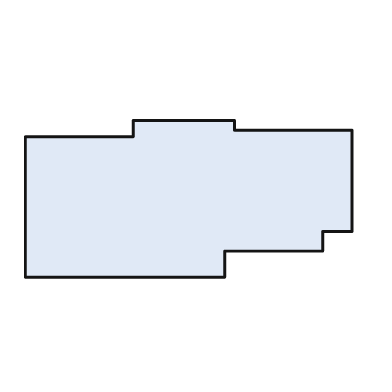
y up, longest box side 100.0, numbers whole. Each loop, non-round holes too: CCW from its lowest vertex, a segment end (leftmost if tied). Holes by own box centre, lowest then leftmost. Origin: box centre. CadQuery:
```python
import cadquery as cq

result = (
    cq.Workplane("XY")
    .moveTo(-50.0, -24.0)
    .lineTo(11.0, -24.0)
    .lineTo(11.0, -16.0)
    .lineTo(41.0, -16.0)
    .lineTo(41.0, -10.0)
    .lineTo(50.0, -10.0)
    .lineTo(50.0, 21.0)
    .lineTo(14.0, 21.0)
    .lineTo(14.0, 24.0)
    .lineTo(-17.0, 24.0)
    .lineTo(-17.0, 19.0)
    .lineTo(-50.0, 19.0)
    .close()
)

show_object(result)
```